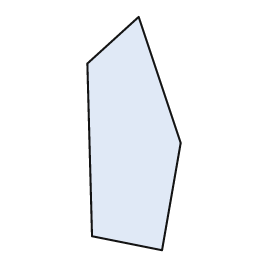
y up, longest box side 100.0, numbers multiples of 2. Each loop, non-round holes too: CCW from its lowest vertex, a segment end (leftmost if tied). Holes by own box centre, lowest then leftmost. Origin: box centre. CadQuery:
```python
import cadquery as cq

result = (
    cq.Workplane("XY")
    .moveTo(12.0, -50.0)
    .lineTo(20.0, -4.0)
    .lineTo(2.0, 50.0)
    .lineTo(-20.0, 30.0)
    .lineTo(-18.0, -44.0)
    .close()
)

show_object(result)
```